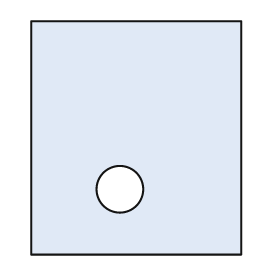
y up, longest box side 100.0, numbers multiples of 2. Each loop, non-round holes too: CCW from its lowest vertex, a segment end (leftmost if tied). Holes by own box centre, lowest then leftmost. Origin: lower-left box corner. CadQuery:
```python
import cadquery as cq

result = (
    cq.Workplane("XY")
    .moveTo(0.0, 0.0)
    .lineTo(90.0, 0.0)
    .lineTo(90.0, 100.0)
    .lineTo(0.0, 100.0)
    .close()
    .moveTo(38.0, 28.0)
    .circle(10.0)
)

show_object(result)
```